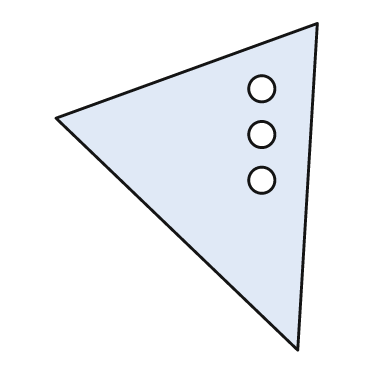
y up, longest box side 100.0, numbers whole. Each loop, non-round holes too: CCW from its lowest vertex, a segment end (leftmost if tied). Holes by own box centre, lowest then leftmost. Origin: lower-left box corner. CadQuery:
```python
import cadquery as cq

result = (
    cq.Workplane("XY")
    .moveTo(74.0, 0.0)
    .lineTo(80.0, 100.0)
    .lineTo(0.0, 71.0)
    .close()
    .moveTo(63.0, 52.0)
    .circle(4.0)
    .moveTo(63.0, 66.0)
    .circle(4.0)
    .moveTo(63.0, 80.0)
    .circle(4.0)
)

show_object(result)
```